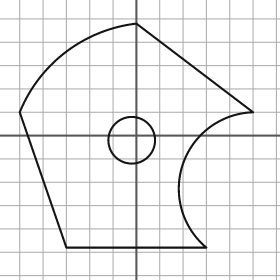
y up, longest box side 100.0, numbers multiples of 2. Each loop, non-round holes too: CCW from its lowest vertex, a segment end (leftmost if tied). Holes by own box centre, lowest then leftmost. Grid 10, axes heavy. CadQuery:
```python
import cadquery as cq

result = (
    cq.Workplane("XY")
    .moveTo(-30.0, -48.0)
    .lineTo(30.0, -48.0)
    .threePointArc((20.0, -12.0), (50.0, 10.0))
    .lineTo(0.0, 48.0)
    .threePointArc((-30.0, 36.0), (-50.0, 10.0))
    .close()
    .moveTo(-2.0, -2.0)
    .circle(10.0)
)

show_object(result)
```